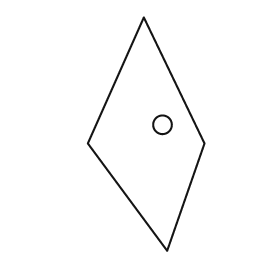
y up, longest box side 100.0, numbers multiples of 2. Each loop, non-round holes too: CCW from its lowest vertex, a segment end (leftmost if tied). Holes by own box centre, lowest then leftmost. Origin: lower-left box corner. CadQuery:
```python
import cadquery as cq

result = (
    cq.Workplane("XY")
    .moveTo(34.0, 0.0)
    .lineTo(50.0, 46.0)
    .lineTo(24.0, 100.0)
    .lineTo(0.0, 46.0)
    .close()
    .moveTo(32.0, 54.0)
    .circle(4.0)
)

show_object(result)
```